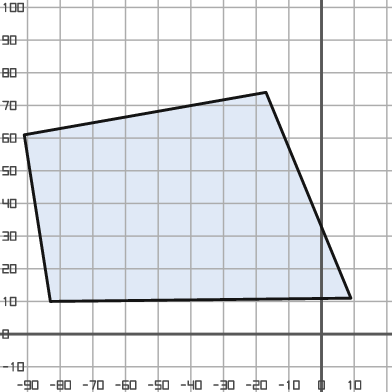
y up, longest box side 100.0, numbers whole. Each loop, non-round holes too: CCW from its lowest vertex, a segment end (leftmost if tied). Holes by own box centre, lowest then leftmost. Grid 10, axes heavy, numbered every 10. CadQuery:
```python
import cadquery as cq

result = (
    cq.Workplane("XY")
    .moveTo(-83.0, 10.0)
    .lineTo(9.0, 11.0)
    .lineTo(-17.0, 74.0)
    .lineTo(-91.0, 61.0)
    .close()
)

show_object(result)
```